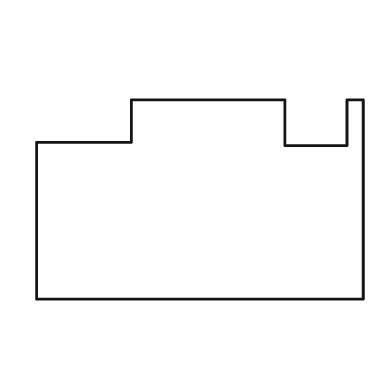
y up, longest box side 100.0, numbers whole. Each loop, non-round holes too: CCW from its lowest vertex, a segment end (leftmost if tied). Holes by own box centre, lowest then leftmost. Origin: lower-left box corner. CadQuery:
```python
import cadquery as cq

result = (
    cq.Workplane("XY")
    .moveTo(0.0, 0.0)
    .lineTo(100.0, 0.0)
    .lineTo(100.0, 61.0)
    .lineTo(95.0, 61.0)
    .lineTo(95.0, 47.0)
    .lineTo(76.0, 47.0)
    .lineTo(76.0, 61.0)
    .lineTo(29.0, 61.0)
    .lineTo(29.0, 48.0)
    .lineTo(0.0, 48.0)
    .close()
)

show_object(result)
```